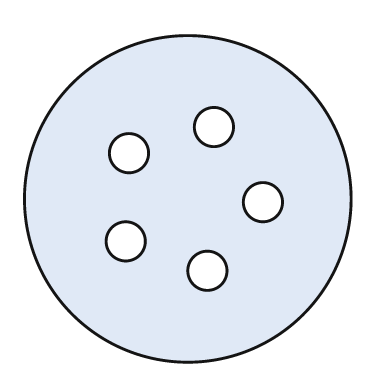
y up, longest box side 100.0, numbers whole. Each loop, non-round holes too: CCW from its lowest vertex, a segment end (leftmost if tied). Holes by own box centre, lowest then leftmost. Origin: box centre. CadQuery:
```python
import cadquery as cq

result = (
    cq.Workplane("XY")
    .moveTo(0.0, 0.0)
    .circle(50.0)
    .moveTo(6.0, -22.0)
    .circle(6.0)
    .moveTo(-19.0, -13.0)
    .circle(6.0)
    .moveTo(23.0, -1.0)
    .circle(6.0)
    .moveTo(-18.0, 14.0)
    .circle(6.0)
    .moveTo(8.0, 22.0)
    .circle(6.0)
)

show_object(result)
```